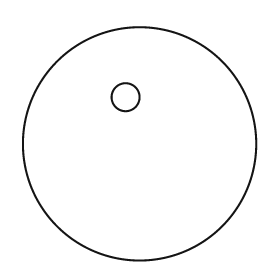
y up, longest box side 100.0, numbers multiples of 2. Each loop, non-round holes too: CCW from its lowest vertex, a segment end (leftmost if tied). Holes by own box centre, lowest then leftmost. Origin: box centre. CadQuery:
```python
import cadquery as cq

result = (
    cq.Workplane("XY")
    .moveTo(0.0, 0.0)
    .circle(50.0)
    .moveTo(-6.0, 20.0)
    .circle(6.0)
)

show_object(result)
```